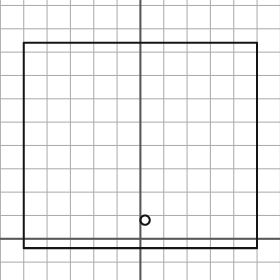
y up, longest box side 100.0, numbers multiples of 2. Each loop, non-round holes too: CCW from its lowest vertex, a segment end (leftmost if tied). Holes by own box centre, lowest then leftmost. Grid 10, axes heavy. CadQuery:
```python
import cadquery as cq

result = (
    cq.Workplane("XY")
    .moveTo(-50.0, -4.0)
    .lineTo(50.0, -4.0)
    .lineTo(50.0, 84.0)
    .lineTo(-50.0, 84.0)
    .close()
    .moveTo(2.0, 8.0)
    .circle(2.0)
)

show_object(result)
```